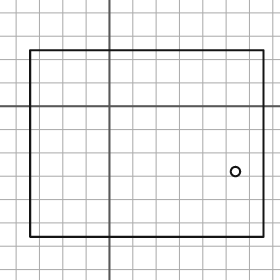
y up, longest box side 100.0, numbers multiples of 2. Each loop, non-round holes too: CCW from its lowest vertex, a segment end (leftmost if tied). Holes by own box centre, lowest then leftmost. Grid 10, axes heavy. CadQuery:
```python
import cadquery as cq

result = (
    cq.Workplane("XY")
    .moveTo(-34.0, -56.0)
    .lineTo(66.0, -56.0)
    .lineTo(66.0, 24.0)
    .lineTo(-34.0, 24.0)
    .close()
    .moveTo(54.0, -28.0)
    .circle(2.0)
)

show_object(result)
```